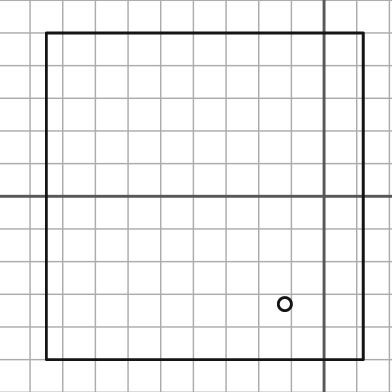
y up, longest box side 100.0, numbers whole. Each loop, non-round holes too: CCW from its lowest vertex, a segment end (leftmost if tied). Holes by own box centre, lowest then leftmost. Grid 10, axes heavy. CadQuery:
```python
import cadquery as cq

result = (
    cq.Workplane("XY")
    .moveTo(-85.0, -50.0)
    .lineTo(12.0, -50.0)
    .lineTo(12.0, 50.0)
    .lineTo(-85.0, 50.0)
    .close()
    .moveTo(-12.0, -33.0)
    .circle(2.0)
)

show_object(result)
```